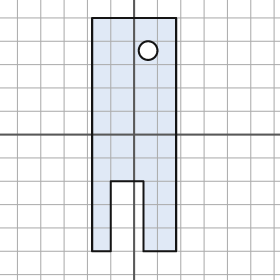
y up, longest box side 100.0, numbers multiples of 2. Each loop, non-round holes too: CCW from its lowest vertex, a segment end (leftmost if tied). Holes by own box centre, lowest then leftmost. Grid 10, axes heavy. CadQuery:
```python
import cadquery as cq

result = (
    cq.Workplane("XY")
    .moveTo(-18.0, -50.0)
    .lineTo(-10.0, -50.0)
    .lineTo(-10.0, -20.0)
    .lineTo(4.0, -20.0)
    .lineTo(4.0, -50.0)
    .lineTo(18.0, -50.0)
    .lineTo(18.0, 50.0)
    .lineTo(-18.0, 50.0)
    .close()
    .moveTo(6.0, 36.0)
    .circle(4.0)
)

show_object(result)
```